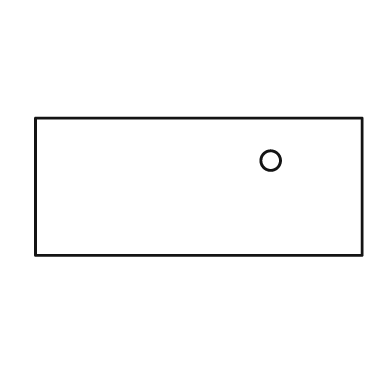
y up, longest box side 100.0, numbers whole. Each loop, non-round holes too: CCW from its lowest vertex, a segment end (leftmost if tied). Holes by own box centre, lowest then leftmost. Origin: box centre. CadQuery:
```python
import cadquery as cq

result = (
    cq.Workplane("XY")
    .moveTo(-50.0, -21.0)
    .lineTo(50.0, -21.0)
    .lineTo(50.0, 21.0)
    .lineTo(-50.0, 21.0)
    .close()
    .moveTo(22.0, 8.0)
    .circle(3.0)
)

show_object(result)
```